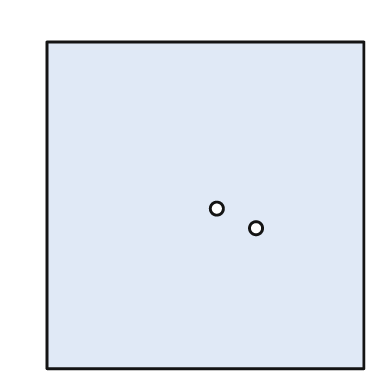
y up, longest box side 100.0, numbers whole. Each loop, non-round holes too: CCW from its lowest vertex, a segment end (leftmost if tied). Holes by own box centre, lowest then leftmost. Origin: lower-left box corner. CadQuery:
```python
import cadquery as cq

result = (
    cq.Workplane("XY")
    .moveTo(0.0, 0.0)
    .lineTo(97.0, 0.0)
    .lineTo(97.0, 100.0)
    .lineTo(0.0, 100.0)
    .close()
    .moveTo(64.0, 43.0)
    .circle(2.0)
    .moveTo(52.0, 49.0)
    .circle(2.0)
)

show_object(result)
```